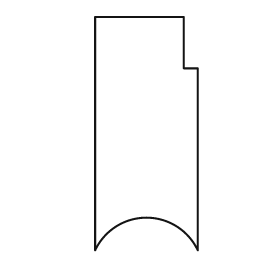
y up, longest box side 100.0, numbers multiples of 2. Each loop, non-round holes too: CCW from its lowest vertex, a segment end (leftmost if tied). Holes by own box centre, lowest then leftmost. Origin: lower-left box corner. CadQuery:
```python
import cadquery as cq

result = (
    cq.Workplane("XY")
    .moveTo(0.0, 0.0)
    .threePointArc((22.0, 14.0), (44.0, 0.0))
    .lineTo(44.0, 78.0)
    .lineTo(38.0, 78.0)
    .lineTo(38.0, 100.0)
    .lineTo(0.0, 100.0)
    .close()
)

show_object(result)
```